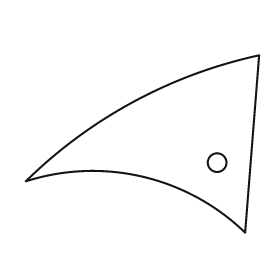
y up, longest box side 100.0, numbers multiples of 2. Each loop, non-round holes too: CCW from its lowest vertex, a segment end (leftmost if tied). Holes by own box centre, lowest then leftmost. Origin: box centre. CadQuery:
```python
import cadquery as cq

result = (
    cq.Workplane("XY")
    .moveTo(44.0, -38.0)
    .lineTo(50.0, 38.0)
    .threePointArc((-4.0, 18.0), (-50.0, -16.0))
    .threePointArc((0.0, -14.0), (44.0, -38.0))
    .close()
    .moveTo(32.0, -8.0)
    .circle(4.0)
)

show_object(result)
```